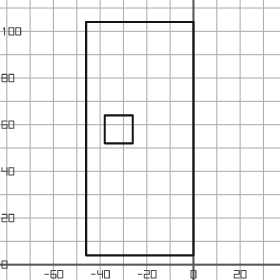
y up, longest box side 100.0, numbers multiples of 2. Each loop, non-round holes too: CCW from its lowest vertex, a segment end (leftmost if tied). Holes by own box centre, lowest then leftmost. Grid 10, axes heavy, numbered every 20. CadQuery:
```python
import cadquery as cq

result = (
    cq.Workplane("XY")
    .moveTo(-46.0, 4.0)
    .lineTo(0.0, 4.0)
    .lineTo(0.0, 104.0)
    .lineTo(-46.0, 104.0)
    .close()
    .moveTo(-38.0, 52.0)
    .lineTo(-26.0, 52.0)
    .lineTo(-26.0, 64.0)
    .lineTo(-38.0, 64.0)
    .close()
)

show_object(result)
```